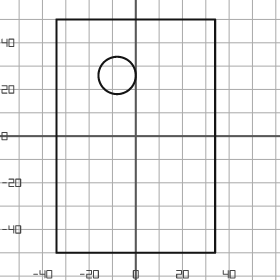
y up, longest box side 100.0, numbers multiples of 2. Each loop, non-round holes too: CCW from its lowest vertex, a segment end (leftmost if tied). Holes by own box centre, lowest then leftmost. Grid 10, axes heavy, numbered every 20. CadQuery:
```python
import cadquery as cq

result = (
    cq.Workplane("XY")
    .moveTo(-34.0, -50.0)
    .lineTo(34.0, -50.0)
    .lineTo(34.0, 50.0)
    .lineTo(-34.0, 50.0)
    .close()
    .moveTo(-8.0, 26.0)
    .circle(8.0)
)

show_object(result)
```